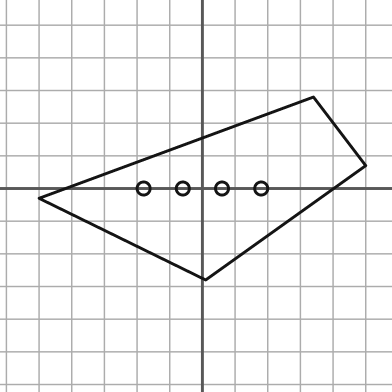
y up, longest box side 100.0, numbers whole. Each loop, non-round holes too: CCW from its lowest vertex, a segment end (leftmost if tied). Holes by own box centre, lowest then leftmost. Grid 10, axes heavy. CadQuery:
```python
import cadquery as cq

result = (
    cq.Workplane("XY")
    .moveTo(1.0, -28.0)
    .lineTo(50.0, 7.0)
    .lineTo(34.0, 28.0)
    .lineTo(-50.0, -3.0)
    .close()
    .moveTo(-18.0, 0.0)
    .circle(2.0)
    .moveTo(-6.0, 0.0)
    .circle(2.0)
    .moveTo(6.0, 0.0)
    .circle(2.0)
    .moveTo(18.0, 0.0)
    .circle(2.0)
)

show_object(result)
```